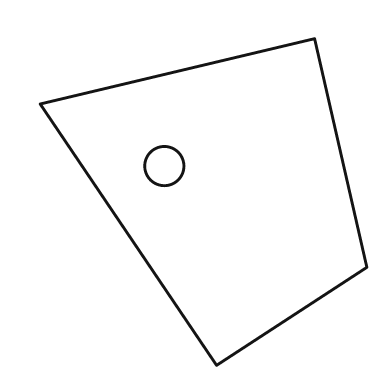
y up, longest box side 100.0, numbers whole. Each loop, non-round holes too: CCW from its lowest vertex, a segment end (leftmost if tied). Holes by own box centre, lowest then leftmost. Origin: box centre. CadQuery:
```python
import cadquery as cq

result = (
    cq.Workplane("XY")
    .moveTo(4.0, -50.0)
    .lineTo(50.0, -20.0)
    .lineTo(34.0, 50.0)
    .lineTo(-50.0, 30.0)
    .close()
    .moveTo(-12.0, 11.0)
    .circle(6.0)
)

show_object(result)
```